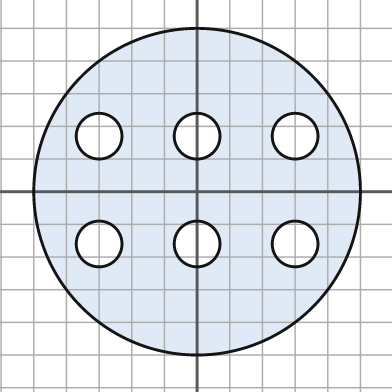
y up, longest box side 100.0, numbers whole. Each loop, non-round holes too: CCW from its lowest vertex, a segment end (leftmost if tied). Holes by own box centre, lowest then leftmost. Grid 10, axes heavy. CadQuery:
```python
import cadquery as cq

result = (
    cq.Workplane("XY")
    .moveTo(0.0, 0.0)
    .circle(50.0)
    .moveTo(-30.0, -16.0)
    .circle(7.0)
    .moveTo(0.0, -16.0)
    .circle(7.0)
    .moveTo(30.0, -16.0)
    .circle(7.0)
    .moveTo(-30.0, 17.0)
    .circle(7.0)
    .moveTo(0.0, 17.0)
    .circle(7.0)
    .moveTo(30.0, 17.0)
    .circle(7.0)
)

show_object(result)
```